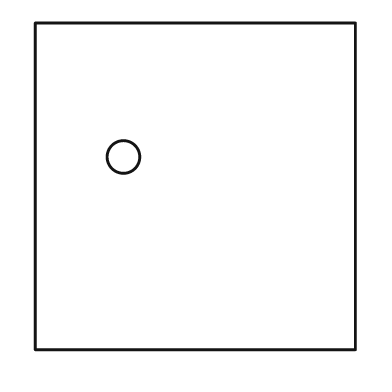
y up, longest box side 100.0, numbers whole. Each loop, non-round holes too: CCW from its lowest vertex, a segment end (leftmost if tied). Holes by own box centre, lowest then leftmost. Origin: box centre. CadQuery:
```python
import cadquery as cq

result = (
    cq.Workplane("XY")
    .moveTo(-49.0, -50.0)
    .lineTo(49.0, -50.0)
    .lineTo(49.0, 50.0)
    .lineTo(-49.0, 50.0)
    .close()
    .moveTo(-22.0, 9.0)
    .circle(5.0)
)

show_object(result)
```